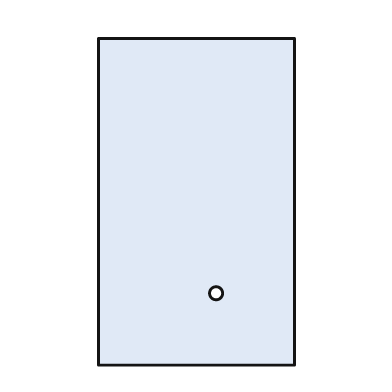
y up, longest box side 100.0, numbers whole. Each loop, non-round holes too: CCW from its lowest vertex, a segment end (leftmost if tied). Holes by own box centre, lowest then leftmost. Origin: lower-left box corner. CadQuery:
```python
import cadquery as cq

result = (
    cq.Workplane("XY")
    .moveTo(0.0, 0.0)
    .lineTo(60.0, 0.0)
    .lineTo(60.0, 100.0)
    .lineTo(0.0, 100.0)
    .close()
    .moveTo(36.0, 22.0)
    .circle(2.0)
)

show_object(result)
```